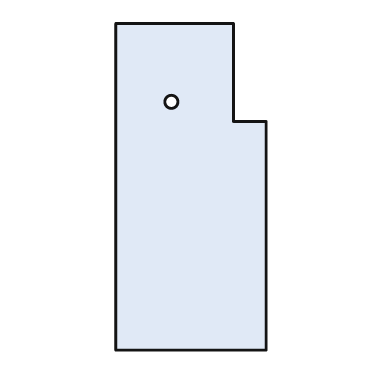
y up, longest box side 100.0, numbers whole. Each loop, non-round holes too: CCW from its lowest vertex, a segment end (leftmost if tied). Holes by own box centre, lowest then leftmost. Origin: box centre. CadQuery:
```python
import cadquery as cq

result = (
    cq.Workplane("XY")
    .moveTo(-23.0, -50.0)
    .lineTo(23.0, -50.0)
    .lineTo(23.0, 20.0)
    .lineTo(13.0, 20.0)
    .lineTo(13.0, 50.0)
    .lineTo(-23.0, 50.0)
    .close()
    .moveTo(-6.0, 26.0)
    .circle(2.0)
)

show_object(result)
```